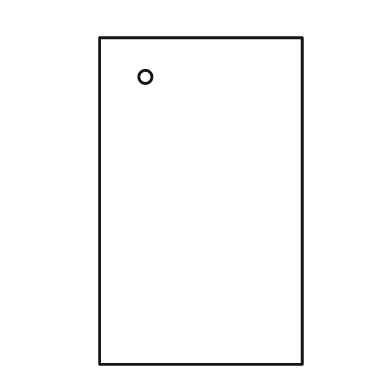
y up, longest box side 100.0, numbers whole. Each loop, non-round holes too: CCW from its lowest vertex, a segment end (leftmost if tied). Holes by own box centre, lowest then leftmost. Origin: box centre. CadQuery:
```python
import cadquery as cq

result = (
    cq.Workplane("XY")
    .moveTo(-31.0, -50.0)
    .lineTo(31.0, -50.0)
    .lineTo(31.0, 50.0)
    .lineTo(-31.0, 50.0)
    .close()
    .moveTo(-17.0, 38.0)
    .circle(2.0)
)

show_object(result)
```